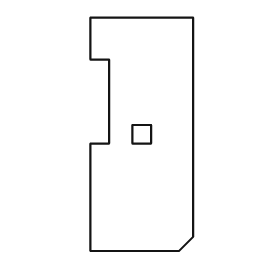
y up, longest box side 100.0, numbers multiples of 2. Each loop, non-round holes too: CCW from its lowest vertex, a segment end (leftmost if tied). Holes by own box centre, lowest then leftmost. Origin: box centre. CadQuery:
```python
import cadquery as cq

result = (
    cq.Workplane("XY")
    .moveTo(-22.0, -50.0)
    .lineTo(16.0, -50.0)
    .lineTo(22.0, -44.0)
    .lineTo(22.0, 50.0)
    .lineTo(-22.0, 50.0)
    .lineTo(-22.0, 32.0)
    .lineTo(-14.0, 32.0)
    .lineTo(-14.0, -4.0)
    .lineTo(-22.0, -4.0)
    .close()
    .moveTo(-4.0, -4.0)
    .lineTo(4.0, -4.0)
    .lineTo(4.0, 4.0)
    .lineTo(-4.0, 4.0)
    .close()
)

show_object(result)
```